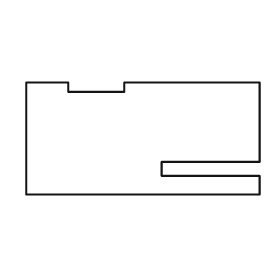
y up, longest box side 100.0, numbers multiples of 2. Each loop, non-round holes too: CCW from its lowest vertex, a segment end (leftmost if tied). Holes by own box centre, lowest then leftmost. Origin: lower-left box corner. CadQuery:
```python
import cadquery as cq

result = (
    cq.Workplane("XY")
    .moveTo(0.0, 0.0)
    .lineTo(100.0, 0.0)
    .lineTo(100.0, 8.0)
    .lineTo(58.0, 8.0)
    .lineTo(58.0, 14.0)
    .lineTo(100.0, 14.0)
    .lineTo(100.0, 48.0)
    .lineTo(42.0, 48.0)
    .lineTo(42.0, 44.0)
    .lineTo(18.0, 44.0)
    .lineTo(18.0, 48.0)
    .lineTo(0.0, 48.0)
    .close()
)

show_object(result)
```